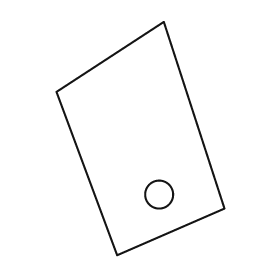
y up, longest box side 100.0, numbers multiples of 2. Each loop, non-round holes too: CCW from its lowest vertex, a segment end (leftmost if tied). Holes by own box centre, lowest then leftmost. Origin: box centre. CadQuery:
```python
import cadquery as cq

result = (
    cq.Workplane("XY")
    .moveTo(-10.0, -50.0)
    .lineTo(36.0, -30.0)
    .lineTo(10.0, 50.0)
    .lineTo(-36.0, 20.0)
    .close()
    .moveTo(8.0, -24.0)
    .circle(6.0)
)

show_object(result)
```